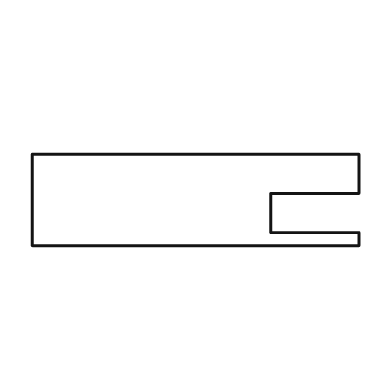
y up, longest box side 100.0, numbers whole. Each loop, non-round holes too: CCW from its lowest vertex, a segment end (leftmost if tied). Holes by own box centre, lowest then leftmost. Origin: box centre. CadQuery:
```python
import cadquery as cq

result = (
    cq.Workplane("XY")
    .moveTo(-50.0, -14.0)
    .lineTo(50.0, -14.0)
    .lineTo(50.0, -10.0)
    .lineTo(23.0, -10.0)
    .lineTo(23.0, 2.0)
    .lineTo(50.0, 2.0)
    .lineTo(50.0, 14.0)
    .lineTo(-50.0, 14.0)
    .close()
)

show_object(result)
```